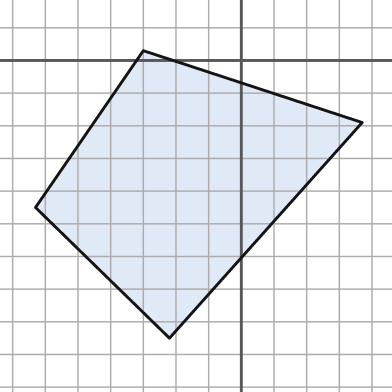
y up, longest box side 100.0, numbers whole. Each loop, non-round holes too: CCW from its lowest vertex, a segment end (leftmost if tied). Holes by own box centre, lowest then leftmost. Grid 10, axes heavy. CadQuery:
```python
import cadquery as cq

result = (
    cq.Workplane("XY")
    .moveTo(-22.0, -85.0)
    .lineTo(37.0, -19.0)
    .lineTo(-30.0, 3.0)
    .lineTo(-63.0, -45.0)
    .close()
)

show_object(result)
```